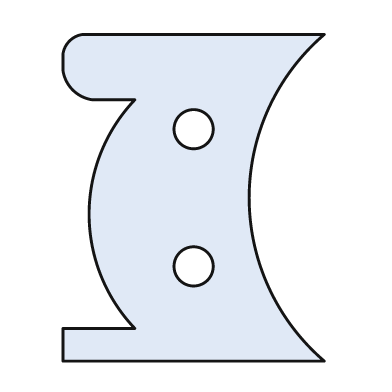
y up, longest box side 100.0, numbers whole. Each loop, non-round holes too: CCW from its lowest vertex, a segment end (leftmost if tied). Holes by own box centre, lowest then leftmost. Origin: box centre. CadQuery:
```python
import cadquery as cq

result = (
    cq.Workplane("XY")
    .moveTo(-40.0, -50.0)
    .lineTo(40.0, -50.0)
    .threePointArc((17.0, 0.0), (40.0, 50.0))
    .lineTo(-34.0, 50.0)
    .threePointArc((-38.0, 48.0), (-40.0, 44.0))
    .lineTo(-40.0, 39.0)
    .threePointArc((-37.0, 33.0), (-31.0, 30.0))
    .lineTo(-18.0, 30.0)
    .threePointArc((-32.0, -5.0), (-18.0, -40.0))
    .lineTo(-40.0, -40.0)
    .close()
    .moveTo(0.0, -21.0)
    .circle(6.0)
    .moveTo(0.0, 21.0)
    .circle(6.0)
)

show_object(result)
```